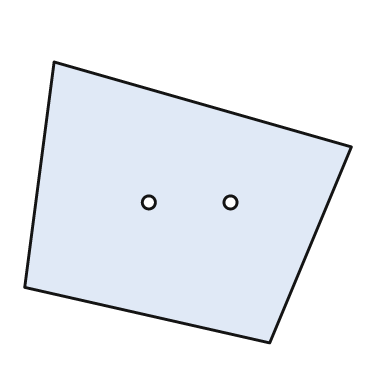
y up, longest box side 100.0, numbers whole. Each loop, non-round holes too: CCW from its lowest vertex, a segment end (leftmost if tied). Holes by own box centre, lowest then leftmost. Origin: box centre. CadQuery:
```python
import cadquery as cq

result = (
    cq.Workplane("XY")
    .moveTo(25.0, -43.0)
    .lineTo(50.0, 17.0)
    .lineTo(-41.0, 43.0)
    .lineTo(-50.0, -26.0)
    .close()
    .moveTo(-12.0, 0.0)
    .circle(2.0)
    .moveTo(13.0, 0.0)
    .circle(2.0)
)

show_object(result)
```